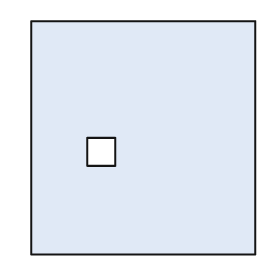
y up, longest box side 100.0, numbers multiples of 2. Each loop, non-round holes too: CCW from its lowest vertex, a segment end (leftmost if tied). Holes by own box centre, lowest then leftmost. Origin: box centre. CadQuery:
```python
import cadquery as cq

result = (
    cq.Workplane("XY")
    .moveTo(-48.0, -50.0)
    .lineTo(48.0, -50.0)
    .lineTo(48.0, 50.0)
    .lineTo(-48.0, 50.0)
    .close()
    .moveTo(-24.0, -12.0)
    .lineTo(-12.0, -12.0)
    .lineTo(-12.0, 0.0)
    .lineTo(-24.0, 0.0)
    .close()
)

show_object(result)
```